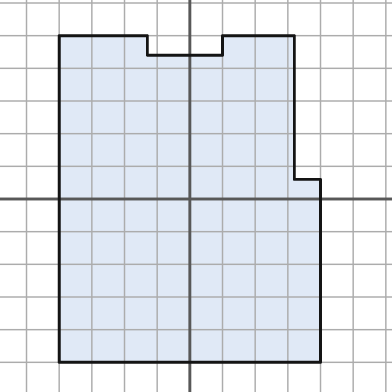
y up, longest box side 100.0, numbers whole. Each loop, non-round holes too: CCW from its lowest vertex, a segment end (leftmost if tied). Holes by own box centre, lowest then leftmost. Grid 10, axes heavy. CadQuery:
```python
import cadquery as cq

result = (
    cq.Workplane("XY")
    .moveTo(-40.0, -50.0)
    .lineTo(40.0, -50.0)
    .lineTo(40.0, 6.0)
    .lineTo(32.0, 6.0)
    .lineTo(32.0, 50.0)
    .lineTo(10.0, 50.0)
    .lineTo(10.0, 44.0)
    .lineTo(-13.0, 44.0)
    .lineTo(-13.0, 50.0)
    .lineTo(-40.0, 50.0)
    .close()
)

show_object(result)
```